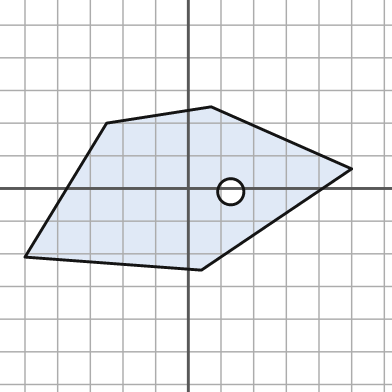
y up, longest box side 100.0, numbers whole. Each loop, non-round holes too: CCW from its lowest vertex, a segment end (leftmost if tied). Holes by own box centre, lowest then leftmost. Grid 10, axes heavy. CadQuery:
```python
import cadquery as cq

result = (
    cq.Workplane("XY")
    .moveTo(4.0, -25.0)
    .lineTo(50.0, 6.0)
    .lineTo(7.0, 25.0)
    .lineTo(-25.0, 20.0)
    .lineTo(-50.0, -21.0)
    .close()
    .moveTo(13.0, -1.0)
    .circle(4.0)
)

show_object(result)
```